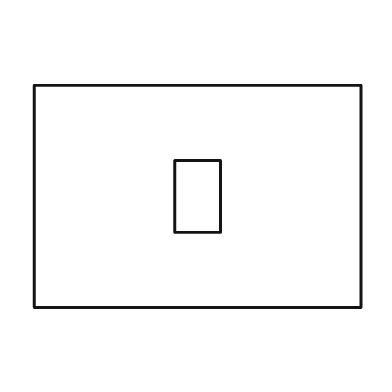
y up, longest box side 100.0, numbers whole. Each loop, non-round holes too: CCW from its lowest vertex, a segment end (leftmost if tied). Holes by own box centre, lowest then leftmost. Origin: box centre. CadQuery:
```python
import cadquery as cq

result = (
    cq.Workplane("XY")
    .moveTo(-50.0, -34.0)
    .lineTo(50.0, -34.0)
    .lineTo(50.0, 34.0)
    .lineTo(-50.0, 34.0)
    .close()
    .moveTo(-7.0, -11.0)
    .lineTo(7.0, -11.0)
    .lineTo(7.0, 11.0)
    .lineTo(-7.0, 11.0)
    .close()
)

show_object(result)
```